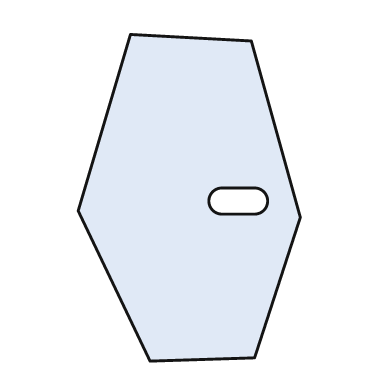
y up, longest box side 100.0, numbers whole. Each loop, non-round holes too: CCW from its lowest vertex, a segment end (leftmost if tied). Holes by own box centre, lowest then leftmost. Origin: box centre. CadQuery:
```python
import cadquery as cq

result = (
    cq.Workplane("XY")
    .moveTo(-12.0, -50.0)
    .lineTo(20.0, -49.0)
    .lineTo(34.0, -6.0)
    .lineTo(19.0, 48.0)
    .lineTo(-18.0, 50.0)
    .lineTo(-34.0, -4.0)
    .close()
    .moveTo(10.0, -5.0)
    .lineTo(20.0, -5.0)
    .threePointArc((24.0, -1.0), (20.0, 3.0))
    .lineTo(10.0, 3.0)
    .threePointArc((6.0, -1.0), (10.0, -5.0))
    .close()
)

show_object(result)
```